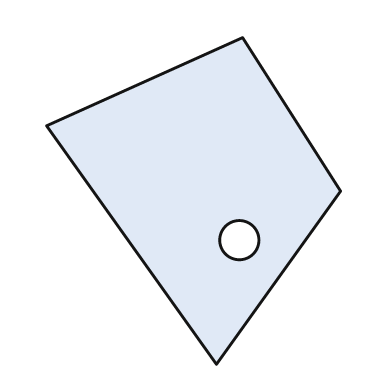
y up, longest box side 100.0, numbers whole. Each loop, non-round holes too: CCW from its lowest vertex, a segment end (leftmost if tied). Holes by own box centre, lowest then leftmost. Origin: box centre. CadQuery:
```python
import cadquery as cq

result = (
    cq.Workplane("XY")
    .moveTo(7.0, -50.0)
    .lineTo(45.0, 3.0)
    .lineTo(15.0, 50.0)
    .lineTo(-45.0, 23.0)
    .close()
    .moveTo(14.0, -12.0)
    .circle(6.0)
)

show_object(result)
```